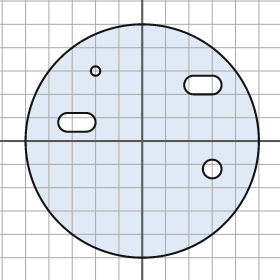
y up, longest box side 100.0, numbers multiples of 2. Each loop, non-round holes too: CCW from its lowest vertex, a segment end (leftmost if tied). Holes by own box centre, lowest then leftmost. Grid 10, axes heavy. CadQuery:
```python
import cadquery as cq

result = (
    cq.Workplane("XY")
    .moveTo(0.0, 0.0)
    .circle(50.0)
    .moveTo(30.0, -12.0)
    .circle(4.0)
    .moveTo(-32.0, 4.0)
    .lineTo(-24.0, 4.0)
    .threePointArc((-20.0, 8.0), (-24.0, 12.0))
    .lineTo(-32.0, 12.0)
    .threePointArc((-36.0, 8.0), (-32.0, 4.0))
    .close()
    .moveTo(22.0, 20.0)
    .lineTo(30.0, 20.0)
    .threePointArc((34.0, 24.0), (30.0, 28.0))
    .lineTo(22.0, 28.0)
    .threePointArc((18.0, 24.0), (22.0, 20.0))
    .close()
    .moveTo(-20.0, 30.0)
    .circle(2.0)
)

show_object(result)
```